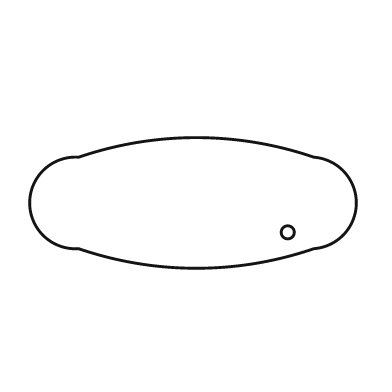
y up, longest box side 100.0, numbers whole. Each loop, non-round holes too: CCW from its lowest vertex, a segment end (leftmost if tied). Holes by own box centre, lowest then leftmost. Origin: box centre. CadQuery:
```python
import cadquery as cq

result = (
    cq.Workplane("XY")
    .moveTo(-35.0, -14.0)
    .threePointArc((1.0, -20.0), (37.0, -14.0))
    .threePointArc((50.0, 0.0), (37.0, 14.0))
    .threePointArc((1.0, 20.0), (-35.0, 14.0))
    .threePointArc((-50.0, 0.0), (-35.0, -14.0))
    .close()
    .moveTo(29.0, -9.0)
    .circle(2.0)
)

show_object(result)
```